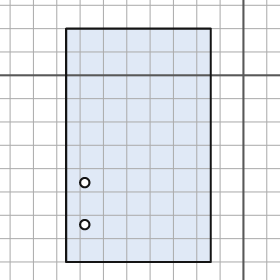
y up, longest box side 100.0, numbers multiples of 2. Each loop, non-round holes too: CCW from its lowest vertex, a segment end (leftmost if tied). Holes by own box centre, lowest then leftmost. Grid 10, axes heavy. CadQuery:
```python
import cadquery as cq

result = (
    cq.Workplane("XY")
    .moveTo(-76.0, -80.0)
    .lineTo(-14.0, -80.0)
    .lineTo(-14.0, 20.0)
    .lineTo(-76.0, 20.0)
    .close()
    .moveTo(-68.0, -64.0)
    .circle(2.0)
    .moveTo(-68.0, -46.0)
    .circle(2.0)
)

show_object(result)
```